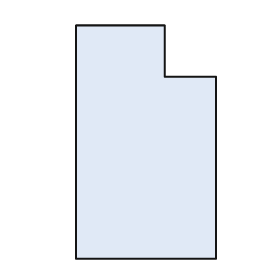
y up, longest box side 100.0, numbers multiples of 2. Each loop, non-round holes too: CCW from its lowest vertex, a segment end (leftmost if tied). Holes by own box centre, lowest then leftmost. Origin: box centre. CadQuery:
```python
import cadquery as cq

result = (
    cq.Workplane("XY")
    .moveTo(-30.0, -50.0)
    .lineTo(30.0, -50.0)
    .lineTo(30.0, 28.0)
    .lineTo(8.0, 28.0)
    .lineTo(8.0, 50.0)
    .lineTo(-30.0, 50.0)
    .close()
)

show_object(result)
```